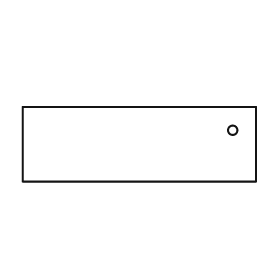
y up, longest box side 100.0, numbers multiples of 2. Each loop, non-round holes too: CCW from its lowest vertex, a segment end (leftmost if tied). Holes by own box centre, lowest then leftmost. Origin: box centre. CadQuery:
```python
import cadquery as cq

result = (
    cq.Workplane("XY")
    .moveTo(-50.0, -16.0)
    .lineTo(50.0, -16.0)
    .lineTo(50.0, 16.0)
    .lineTo(-50.0, 16.0)
    .close()
    .moveTo(40.0, 6.0)
    .circle(2.0)
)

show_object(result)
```